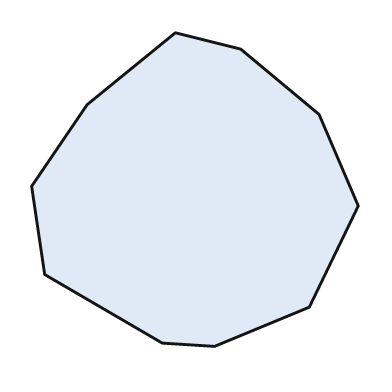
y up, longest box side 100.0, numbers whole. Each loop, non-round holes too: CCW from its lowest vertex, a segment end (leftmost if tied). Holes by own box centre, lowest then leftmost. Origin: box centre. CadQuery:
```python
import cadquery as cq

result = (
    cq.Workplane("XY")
    .moveTo(6.0, -48.0)
    .lineTo(35.0, -36.0)
    .lineTo(50.0, -5.0)
    .lineTo(38.0, 23.0)
    .lineTo(14.0, 43.0)
    .lineTo(-6.0, 48.0)
    .lineTo(-33.0, 26.0)
    .lineTo(-50.0, 1.0)
    .lineTo(-46.0, -26.0)
    .lineTo(-10.0, -47.0)
    .close()
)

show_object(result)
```